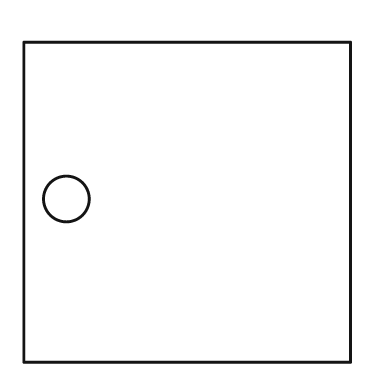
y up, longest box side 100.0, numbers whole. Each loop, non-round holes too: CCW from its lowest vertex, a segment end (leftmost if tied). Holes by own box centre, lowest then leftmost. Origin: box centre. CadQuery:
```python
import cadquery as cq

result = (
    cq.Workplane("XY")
    .moveTo(-50.0, -49.0)
    .lineTo(50.0, -49.0)
    .lineTo(50.0, 49.0)
    .lineTo(-50.0, 49.0)
    .close()
    .moveTo(-37.0, 1.0)
    .circle(7.0)
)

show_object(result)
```